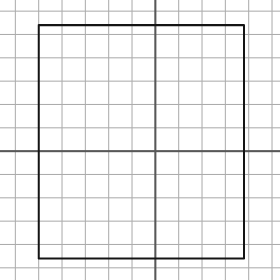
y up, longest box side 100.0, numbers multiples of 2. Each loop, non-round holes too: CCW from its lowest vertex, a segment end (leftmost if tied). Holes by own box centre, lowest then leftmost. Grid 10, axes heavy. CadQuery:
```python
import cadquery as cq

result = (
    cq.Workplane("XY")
    .moveTo(-50.0, -46.0)
    .lineTo(38.0, -46.0)
    .lineTo(38.0, 54.0)
    .lineTo(-50.0, 54.0)
    .close()
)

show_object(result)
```